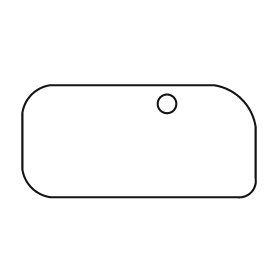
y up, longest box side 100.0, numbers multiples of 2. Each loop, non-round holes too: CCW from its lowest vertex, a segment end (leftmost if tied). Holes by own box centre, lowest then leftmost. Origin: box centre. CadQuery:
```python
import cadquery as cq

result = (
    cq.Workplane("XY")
    .moveTo(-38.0, -24.0)
    .lineTo(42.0, -24.0)
    .threePointArc((48.0, -22.0), (50.0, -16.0))
    .lineTo(50.0, 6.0)
    .threePointArc((44.0, 18.0), (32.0, 24.0))
    .lineTo(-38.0, 24.0)
    .threePointArc((-46.0, 20.0), (-50.0, 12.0))
    .lineTo(-50.0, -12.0)
    .threePointArc((-46.0, -20.0), (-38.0, -24.0))
    .close()
    .moveTo(12.0, 16.0)
    .circle(4.0)
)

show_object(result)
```